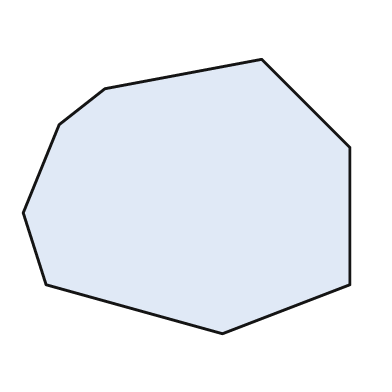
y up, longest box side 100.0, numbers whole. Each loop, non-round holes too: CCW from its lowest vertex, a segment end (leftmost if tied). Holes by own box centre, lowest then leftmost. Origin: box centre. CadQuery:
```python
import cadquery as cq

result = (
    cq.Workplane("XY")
    .moveTo(11.0, -42.0)
    .lineTo(50.0, -27.0)
    .lineTo(50.0, 15.0)
    .lineTo(23.0, 42.0)
    .lineTo(-25.0, 33.0)
    .lineTo(-39.0, 22.0)
    .lineTo(-50.0, -5.0)
    .lineTo(-43.0, -27.0)
    .close()
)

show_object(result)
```